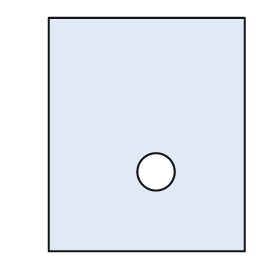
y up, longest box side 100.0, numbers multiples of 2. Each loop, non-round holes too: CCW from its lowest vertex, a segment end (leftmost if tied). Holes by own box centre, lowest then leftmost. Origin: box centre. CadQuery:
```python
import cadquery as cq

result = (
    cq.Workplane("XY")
    .moveTo(-42.0, -50.0)
    .lineTo(42.0, -50.0)
    .lineTo(42.0, 50.0)
    .lineTo(-42.0, 50.0)
    .close()
    .moveTo(4.0, -16.0)
    .circle(8.0)
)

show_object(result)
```